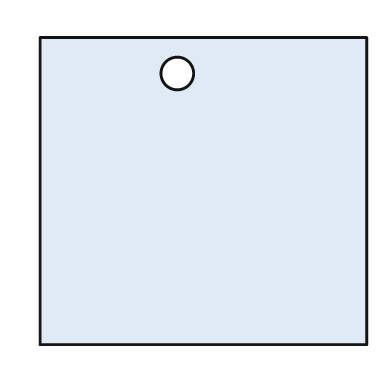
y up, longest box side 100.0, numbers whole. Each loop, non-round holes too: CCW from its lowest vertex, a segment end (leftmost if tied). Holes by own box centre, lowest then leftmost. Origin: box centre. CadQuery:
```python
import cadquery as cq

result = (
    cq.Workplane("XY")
    .moveTo(-50.0, -47.0)
    .lineTo(50.0, -47.0)
    .lineTo(50.0, 47.0)
    .lineTo(-50.0, 47.0)
    .close()
    .moveTo(-8.0, 36.0)
    .circle(5.0)
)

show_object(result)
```